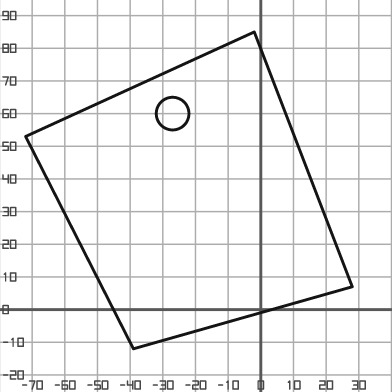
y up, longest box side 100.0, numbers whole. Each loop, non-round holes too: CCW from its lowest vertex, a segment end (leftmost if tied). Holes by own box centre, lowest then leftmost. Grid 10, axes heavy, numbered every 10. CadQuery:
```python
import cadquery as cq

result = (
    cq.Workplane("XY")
    .moveTo(-39.0, -12.0)
    .lineTo(28.0, 7.0)
    .lineTo(-2.0, 85.0)
    .lineTo(-72.0, 53.0)
    .close()
    .moveTo(-27.0, 60.0)
    .circle(5.0)
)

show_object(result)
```